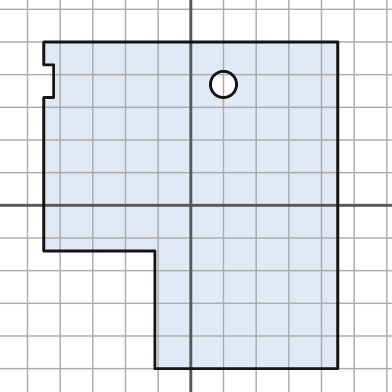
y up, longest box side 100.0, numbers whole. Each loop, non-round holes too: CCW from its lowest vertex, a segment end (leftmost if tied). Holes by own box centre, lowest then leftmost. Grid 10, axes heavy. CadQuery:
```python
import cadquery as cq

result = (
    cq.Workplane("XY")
    .moveTo(-11.0, -50.0)
    .lineTo(45.0, -50.0)
    .lineTo(45.0, 50.0)
    .lineTo(-45.0, 50.0)
    .lineTo(-45.0, 43.0)
    .lineTo(-42.0, 43.0)
    .lineTo(-42.0, 33.0)
    .lineTo(-45.0, 33.0)
    .lineTo(-45.0, -14.0)
    .lineTo(-11.0, -14.0)
    .close()
    .moveTo(10.0, 37.0)
    .circle(4.0)
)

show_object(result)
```